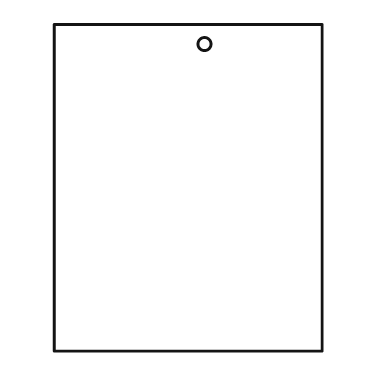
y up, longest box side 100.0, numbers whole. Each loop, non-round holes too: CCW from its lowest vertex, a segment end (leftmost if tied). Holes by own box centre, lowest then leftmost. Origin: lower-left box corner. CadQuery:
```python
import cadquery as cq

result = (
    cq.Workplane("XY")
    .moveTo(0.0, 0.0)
    .lineTo(82.0, 0.0)
    .lineTo(82.0, 100.0)
    .lineTo(0.0, 100.0)
    .close()
    .moveTo(46.0, 94.0)
    .circle(2.0)
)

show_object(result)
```